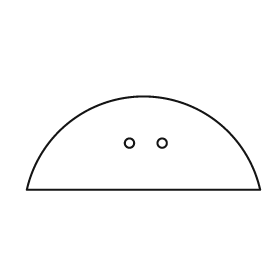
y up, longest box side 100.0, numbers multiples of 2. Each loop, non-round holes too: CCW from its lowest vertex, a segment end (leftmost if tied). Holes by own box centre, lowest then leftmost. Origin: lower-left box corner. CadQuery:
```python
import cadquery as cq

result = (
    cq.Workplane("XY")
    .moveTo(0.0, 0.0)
    .lineTo(100.0, 0.0)
    .threePointArc((50.0, 40.0), (0.0, 0.0))
    .close()
    .moveTo(44.0, 20.0)
    .circle(2.0)
    .moveTo(58.0, 20.0)
    .circle(2.0)
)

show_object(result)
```